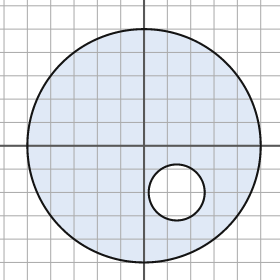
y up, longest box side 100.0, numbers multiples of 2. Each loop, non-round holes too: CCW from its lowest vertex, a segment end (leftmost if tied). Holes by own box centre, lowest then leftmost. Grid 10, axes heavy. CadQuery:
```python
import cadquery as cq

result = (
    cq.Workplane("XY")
    .moveTo(0.0, 0.0)
    .circle(50.0)
    .moveTo(14.0, -20.0)
    .circle(12.0)
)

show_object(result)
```